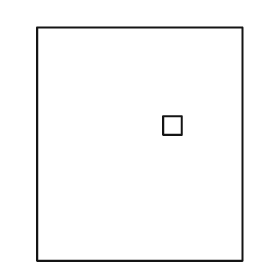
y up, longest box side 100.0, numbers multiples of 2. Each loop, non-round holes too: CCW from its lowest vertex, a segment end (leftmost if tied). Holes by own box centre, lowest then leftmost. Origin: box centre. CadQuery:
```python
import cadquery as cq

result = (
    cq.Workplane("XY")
    .moveTo(-44.0, -50.0)
    .lineTo(44.0, -50.0)
    .lineTo(44.0, 50.0)
    .lineTo(-44.0, 50.0)
    .close()
    .moveTo(10.0, 4.0)
    .lineTo(18.0, 4.0)
    .lineTo(18.0, 12.0)
    .lineTo(10.0, 12.0)
    .close()
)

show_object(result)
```